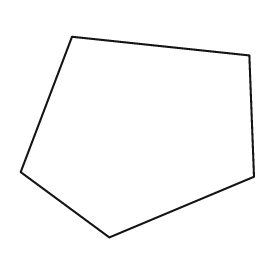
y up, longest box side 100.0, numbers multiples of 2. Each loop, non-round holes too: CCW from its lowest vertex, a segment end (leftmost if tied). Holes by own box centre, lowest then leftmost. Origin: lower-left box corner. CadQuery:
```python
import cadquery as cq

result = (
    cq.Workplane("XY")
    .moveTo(38.0, 0.0)
    .lineTo(100.0, 26.0)
    .lineTo(98.0, 78.0)
    .lineTo(22.0, 86.0)
    .lineTo(0.0, 28.0)
    .close()
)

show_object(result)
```